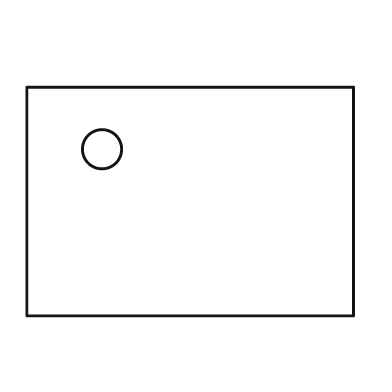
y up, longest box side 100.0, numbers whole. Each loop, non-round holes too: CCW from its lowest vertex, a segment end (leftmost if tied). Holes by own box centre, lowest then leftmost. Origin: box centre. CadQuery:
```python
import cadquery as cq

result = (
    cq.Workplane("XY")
    .moveTo(-50.0, -35.0)
    .lineTo(50.0, -35.0)
    .lineTo(50.0, 35.0)
    .lineTo(-50.0, 35.0)
    .close()
    .moveTo(-27.0, 16.0)
    .circle(6.0)
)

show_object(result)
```